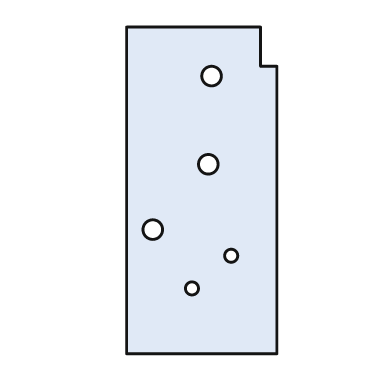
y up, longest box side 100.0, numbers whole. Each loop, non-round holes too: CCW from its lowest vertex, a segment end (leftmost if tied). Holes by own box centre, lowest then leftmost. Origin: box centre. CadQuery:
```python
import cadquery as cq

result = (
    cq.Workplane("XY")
    .moveTo(-23.0, -50.0)
    .lineTo(23.0, -50.0)
    .lineTo(23.0, 38.0)
    .lineTo(18.0, 38.0)
    .lineTo(18.0, 50.0)
    .lineTo(-23.0, 50.0)
    .close()
    .moveTo(-3.0, -30.0)
    .circle(2.0)
    .moveTo(9.0, -20.0)
    .circle(2.0)
    .moveTo(-15.0, -12.0)
    .circle(3.0)
    .moveTo(2.0, 8.0)
    .circle(3.0)
    .moveTo(3.0, 35.0)
    .circle(3.0)
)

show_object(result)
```